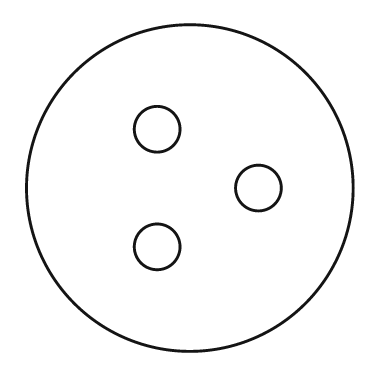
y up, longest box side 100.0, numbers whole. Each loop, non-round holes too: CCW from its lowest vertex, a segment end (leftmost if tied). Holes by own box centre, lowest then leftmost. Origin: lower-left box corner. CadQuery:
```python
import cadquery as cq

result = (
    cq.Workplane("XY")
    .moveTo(50.0, 50.0)
    .circle(50.0)
    .moveTo(40.0, 32.0)
    .circle(7.0)
    .moveTo(71.0, 50.0)
    .circle(7.0)
    .moveTo(40.0, 68.0)
    .circle(7.0)
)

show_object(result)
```